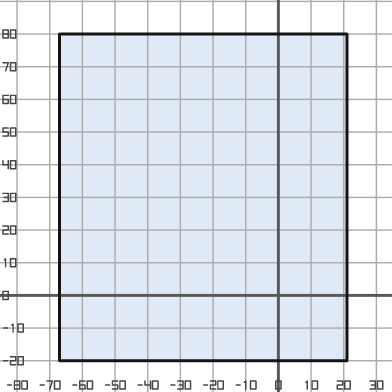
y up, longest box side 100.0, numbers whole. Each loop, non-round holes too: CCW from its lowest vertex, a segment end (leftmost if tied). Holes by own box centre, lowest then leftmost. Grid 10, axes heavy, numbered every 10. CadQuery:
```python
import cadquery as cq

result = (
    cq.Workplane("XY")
    .moveTo(-67.0, -20.0)
    .lineTo(21.0, -20.0)
    .lineTo(21.0, 80.0)
    .lineTo(-67.0, 80.0)
    .close()
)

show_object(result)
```